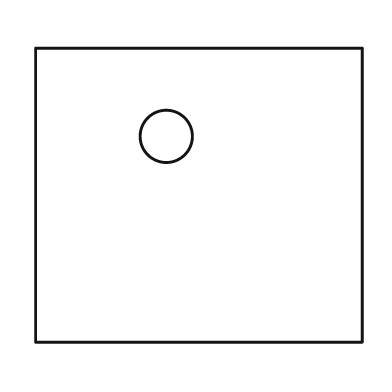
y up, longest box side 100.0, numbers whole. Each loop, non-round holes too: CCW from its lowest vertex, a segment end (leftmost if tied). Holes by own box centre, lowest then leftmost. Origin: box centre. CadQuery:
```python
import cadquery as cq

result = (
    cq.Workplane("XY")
    .moveTo(-50.0, -45.0)
    .lineTo(50.0, -45.0)
    .lineTo(50.0, 45.0)
    .lineTo(-50.0, 45.0)
    .close()
    .moveTo(-10.0, 18.0)
    .circle(8.0)
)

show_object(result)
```